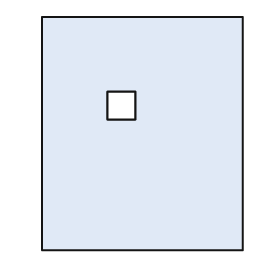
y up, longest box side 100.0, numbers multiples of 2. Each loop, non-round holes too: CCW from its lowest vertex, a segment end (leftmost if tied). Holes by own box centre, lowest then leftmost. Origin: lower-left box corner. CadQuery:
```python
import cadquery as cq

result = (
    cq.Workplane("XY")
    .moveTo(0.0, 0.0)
    .lineTo(86.0, 0.0)
    .lineTo(86.0, 100.0)
    .lineTo(0.0, 100.0)
    .close()
    .moveTo(28.0, 56.0)
    .lineTo(40.0, 56.0)
    .lineTo(40.0, 68.0)
    .lineTo(28.0, 68.0)
    .close()
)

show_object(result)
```